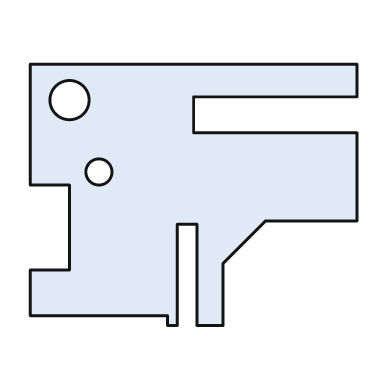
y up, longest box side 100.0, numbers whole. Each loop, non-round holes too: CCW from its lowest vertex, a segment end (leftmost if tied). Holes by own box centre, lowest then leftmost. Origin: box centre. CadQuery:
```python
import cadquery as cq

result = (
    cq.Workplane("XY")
    .moveTo(-8.0, -40.0)
    .lineTo(-5.0, -40.0)
    .lineTo(-5.0, -9.0)
    .lineTo(1.0, -9.0)
    .lineTo(1.0, -40.0)
    .lineTo(9.0, -40.0)
    .lineTo(9.0, -21.0)
    .lineTo(22.0, -8.0)
    .lineTo(50.0, -8.0)
    .lineTo(50.0, 19.0)
    .lineTo(0.0, 19.0)
    .lineTo(0.0, 30.0)
    .lineTo(50.0, 30.0)
    .lineTo(50.0, 40.0)
    .lineTo(-50.0, 40.0)
    .lineTo(-50.0, 3.0)
    .lineTo(-38.0, 3.0)
    .lineTo(-38.0, -23.0)
    .lineTo(-50.0, -23.0)
    .lineTo(-50.0, -37.0)
    .lineTo(-8.0, -37.0)
    .close()
    .moveTo(-29.0, 7.0)
    .circle(4.0)
    .moveTo(-38.0, 29.0)
    .circle(6.0)
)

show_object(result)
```